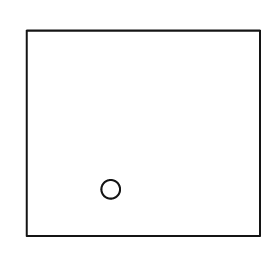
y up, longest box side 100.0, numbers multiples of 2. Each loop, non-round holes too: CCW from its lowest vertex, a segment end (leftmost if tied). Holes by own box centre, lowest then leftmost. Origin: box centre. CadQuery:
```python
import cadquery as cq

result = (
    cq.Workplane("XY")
    .moveTo(-50.0, -44.0)
    .lineTo(50.0, -44.0)
    .lineTo(50.0, 44.0)
    .lineTo(-50.0, 44.0)
    .close()
    .moveTo(-14.0, -24.0)
    .circle(4.0)
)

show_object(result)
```